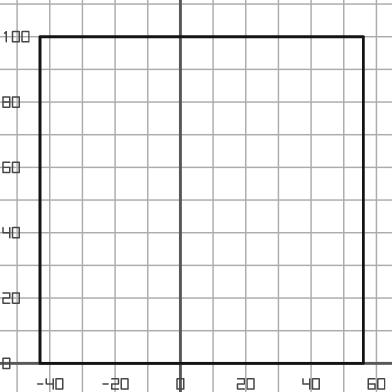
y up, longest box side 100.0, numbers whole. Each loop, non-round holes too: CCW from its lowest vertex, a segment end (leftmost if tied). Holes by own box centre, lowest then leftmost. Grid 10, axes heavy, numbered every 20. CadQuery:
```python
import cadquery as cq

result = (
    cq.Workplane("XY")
    .moveTo(-43.0, 0.0)
    .lineTo(56.0, 0.0)
    .lineTo(56.0, 100.0)
    .lineTo(-43.0, 100.0)
    .close()
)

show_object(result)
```